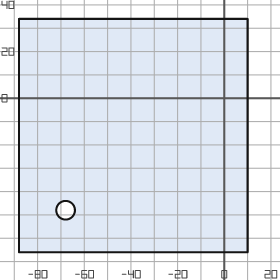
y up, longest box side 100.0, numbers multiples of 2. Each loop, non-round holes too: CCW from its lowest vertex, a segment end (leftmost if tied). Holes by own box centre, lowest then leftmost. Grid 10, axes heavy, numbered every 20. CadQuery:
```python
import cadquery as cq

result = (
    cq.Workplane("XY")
    .moveTo(-88.0, -66.0)
    .lineTo(10.0, -66.0)
    .lineTo(10.0, 34.0)
    .lineTo(-88.0, 34.0)
    .close()
    .moveTo(-68.0, -48.0)
    .circle(4.0)
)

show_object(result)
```